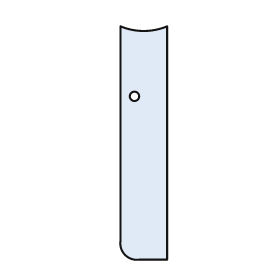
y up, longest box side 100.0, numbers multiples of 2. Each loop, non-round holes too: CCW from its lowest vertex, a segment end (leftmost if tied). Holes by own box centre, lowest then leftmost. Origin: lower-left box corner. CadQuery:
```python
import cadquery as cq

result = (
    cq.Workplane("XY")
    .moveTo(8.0, 0.0)
    .lineTo(20.0, 0.0)
    .lineTo(20.0, 100.0)
    .threePointArc((10.0, 98.0), (0.0, 100.0))
    .lineTo(0.0, 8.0)
    .threePointArc((2.0, 2.0), (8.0, 0.0))
    .close()
    .moveTo(6.0, 70.0)
    .circle(2.0)
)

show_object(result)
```